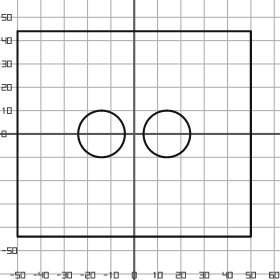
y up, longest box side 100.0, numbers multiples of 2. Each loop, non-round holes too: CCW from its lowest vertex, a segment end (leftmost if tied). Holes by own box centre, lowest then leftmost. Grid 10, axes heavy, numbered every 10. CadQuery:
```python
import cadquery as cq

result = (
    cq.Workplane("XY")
    .moveTo(-50.0, -44.0)
    .lineTo(50.0, -44.0)
    .lineTo(50.0, 44.0)
    .lineTo(-50.0, 44.0)
    .close()
    .moveTo(-14.0, 0.0)
    .circle(10.0)
    .moveTo(14.0, 0.0)
    .circle(10.0)
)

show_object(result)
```